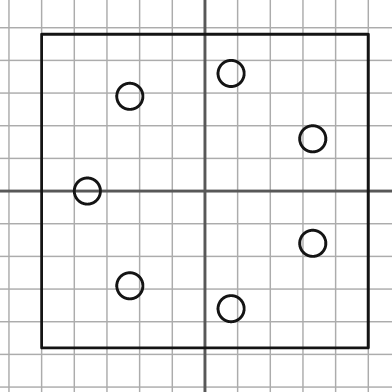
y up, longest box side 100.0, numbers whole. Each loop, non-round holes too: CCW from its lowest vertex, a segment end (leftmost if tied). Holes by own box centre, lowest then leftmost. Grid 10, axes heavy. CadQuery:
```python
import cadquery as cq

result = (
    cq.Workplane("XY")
    .moveTo(-50.0, -48.0)
    .lineTo(50.0, -48.0)
    .lineTo(50.0, 48.0)
    .lineTo(-50.0, 48.0)
    .close()
    .moveTo(8.0, -36.0)
    .circle(4.0)
    .moveTo(-23.0, -29.0)
    .circle(4.0)
    .moveTo(33.0, -16.0)
    .circle(4.0)
    .moveTo(-36.0, 0.0)
    .circle(4.0)
    .moveTo(33.0, 16.0)
    .circle(4.0)
    .moveTo(-23.0, 29.0)
    .circle(4.0)
    .moveTo(8.0, 36.0)
    .circle(4.0)
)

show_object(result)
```